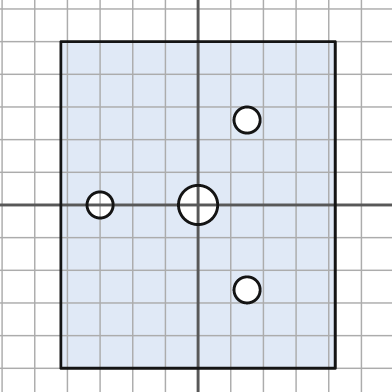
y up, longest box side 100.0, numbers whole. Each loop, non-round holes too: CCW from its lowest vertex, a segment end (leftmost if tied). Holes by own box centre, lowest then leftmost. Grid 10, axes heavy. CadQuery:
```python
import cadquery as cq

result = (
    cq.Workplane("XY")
    .moveTo(-42.0, -50.0)
    .lineTo(42.0, -50.0)
    .lineTo(42.0, 50.0)
    .lineTo(-42.0, 50.0)
    .close()
    .moveTo(15.0, -26.0)
    .circle(4.0)
    .moveTo(-30.0, 0.0)
    .circle(4.0)
    .moveTo(0.0, 0.0)
    .circle(6.0)
    .moveTo(15.0, 26.0)
    .circle(4.0)
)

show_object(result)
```